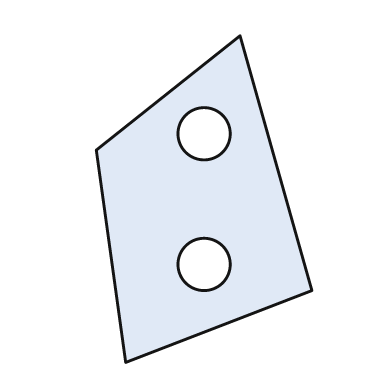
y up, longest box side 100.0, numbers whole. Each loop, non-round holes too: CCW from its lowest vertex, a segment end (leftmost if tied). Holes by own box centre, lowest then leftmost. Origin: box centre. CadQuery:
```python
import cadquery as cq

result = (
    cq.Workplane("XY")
    .moveTo(-24.0, -50.0)
    .lineTo(33.0, -28.0)
    .lineTo(11.0, 50.0)
    .lineTo(-33.0, 15.0)
    .close()
    .moveTo(0.0, -20.0)
    .circle(8.0)
    .moveTo(0.0, 20.0)
    .circle(8.0)
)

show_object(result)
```